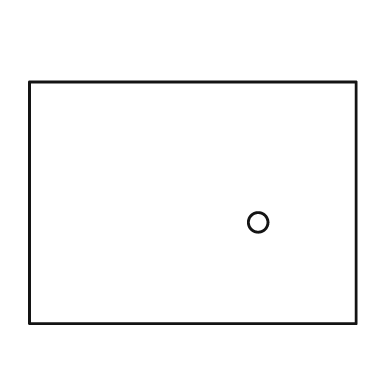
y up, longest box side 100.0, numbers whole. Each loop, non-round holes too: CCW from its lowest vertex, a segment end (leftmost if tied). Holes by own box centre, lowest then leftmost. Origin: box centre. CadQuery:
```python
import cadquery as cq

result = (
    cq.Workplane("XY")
    .moveTo(-50.0, -37.0)
    .lineTo(50.0, -37.0)
    .lineTo(50.0, 37.0)
    .lineTo(-50.0, 37.0)
    .close()
    .moveTo(20.0, -6.0)
    .circle(3.0)
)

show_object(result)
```